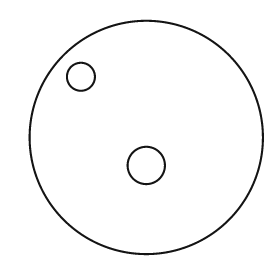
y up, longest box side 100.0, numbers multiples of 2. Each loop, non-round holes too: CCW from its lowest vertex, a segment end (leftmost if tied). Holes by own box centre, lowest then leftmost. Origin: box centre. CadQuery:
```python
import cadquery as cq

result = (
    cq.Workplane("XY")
    .moveTo(0.0, 0.0)
    .circle(50.0)
    .moveTo(0.0, -12.0)
    .circle(8.0)
    .moveTo(-28.0, 26.0)
    .circle(6.0)
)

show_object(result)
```